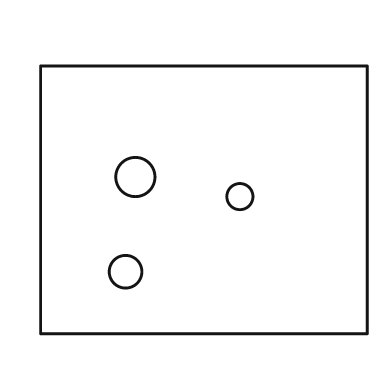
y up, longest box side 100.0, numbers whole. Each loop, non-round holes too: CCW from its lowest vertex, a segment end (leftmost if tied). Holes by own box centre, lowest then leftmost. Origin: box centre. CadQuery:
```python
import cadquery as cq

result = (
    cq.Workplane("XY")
    .moveTo(-50.0, -41.0)
    .lineTo(50.0, -41.0)
    .lineTo(50.0, 41.0)
    .lineTo(-50.0, 41.0)
    .close()
    .moveTo(-24.0, -22.0)
    .circle(5.0)
    .moveTo(11.0, 1.0)
    .circle(4.0)
    .moveTo(-21.0, 7.0)
    .circle(6.0)
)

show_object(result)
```